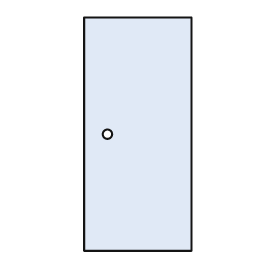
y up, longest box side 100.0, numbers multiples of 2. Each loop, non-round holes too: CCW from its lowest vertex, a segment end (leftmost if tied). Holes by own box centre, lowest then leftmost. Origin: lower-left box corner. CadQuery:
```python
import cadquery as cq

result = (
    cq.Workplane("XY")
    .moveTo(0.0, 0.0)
    .lineTo(46.0, 0.0)
    .lineTo(46.0, 100.0)
    .lineTo(0.0, 100.0)
    .close()
    .moveTo(10.0, 50.0)
    .circle(2.0)
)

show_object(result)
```